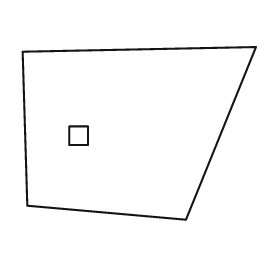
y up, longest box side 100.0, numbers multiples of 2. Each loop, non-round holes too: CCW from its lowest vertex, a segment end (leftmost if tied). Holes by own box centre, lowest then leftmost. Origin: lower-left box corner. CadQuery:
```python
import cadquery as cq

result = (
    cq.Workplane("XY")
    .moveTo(70.0, 0.0)
    .lineTo(100.0, 74.0)
    .lineTo(0.0, 72.0)
    .lineTo(2.0, 6.0)
    .close()
    .moveTo(20.0, 32.0)
    .lineTo(28.0, 32.0)
    .lineTo(28.0, 40.0)
    .lineTo(20.0, 40.0)
    .close()
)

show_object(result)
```